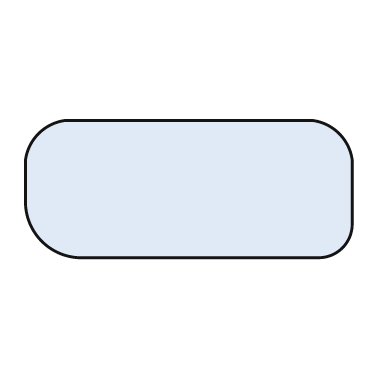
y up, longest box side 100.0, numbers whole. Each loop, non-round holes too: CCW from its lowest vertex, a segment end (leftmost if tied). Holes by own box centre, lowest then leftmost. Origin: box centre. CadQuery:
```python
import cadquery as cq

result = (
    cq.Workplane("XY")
    .moveTo(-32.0, -21.0)
    .lineTo(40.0, -21.0)
    .threePointArc((47.0, -18.0), (50.0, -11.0))
    .lineTo(50.0, 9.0)
    .threePointArc((46.0, 17.0), (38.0, 21.0))
    .lineTo(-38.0, 21.0)
    .threePointArc((-46.0, 17.0), (-50.0, 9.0))
    .lineTo(-50.0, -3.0)
    .threePointArc((-45.0, -16.0), (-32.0, -21.0))
    .close()
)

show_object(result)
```